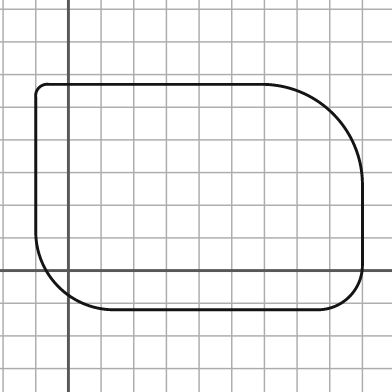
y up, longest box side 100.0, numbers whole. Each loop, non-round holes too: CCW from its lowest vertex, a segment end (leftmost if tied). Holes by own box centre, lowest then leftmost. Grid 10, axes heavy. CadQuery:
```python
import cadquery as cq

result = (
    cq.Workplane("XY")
    .moveTo(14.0, -12.0)
    .lineTo(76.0, -12.0)
    .threePointArc((86.0, -8.0), (90.0, 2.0))
    .lineTo(90.0, 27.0)
    .threePointArc((81.0, 48.0), (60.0, 57.0))
    .lineTo(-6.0, 57.0)
    .threePointArc((-9.0, 56.0), (-10.0, 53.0))
    .lineTo(-10.0, 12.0)
    .threePointArc((-3.0, -5.0), (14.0, -12.0))
    .close()
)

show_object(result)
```